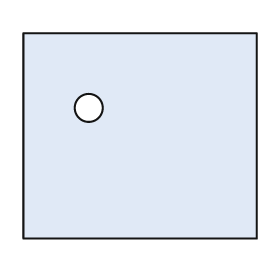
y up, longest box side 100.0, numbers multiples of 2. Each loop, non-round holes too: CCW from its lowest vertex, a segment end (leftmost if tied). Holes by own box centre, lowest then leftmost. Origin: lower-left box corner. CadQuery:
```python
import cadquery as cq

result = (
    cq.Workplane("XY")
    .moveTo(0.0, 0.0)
    .lineTo(100.0, 0.0)
    .lineTo(100.0, 88.0)
    .lineTo(0.0, 88.0)
    .close()
    .moveTo(28.0, 56.0)
    .circle(6.0)
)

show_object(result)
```